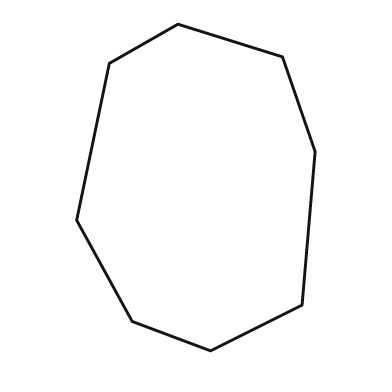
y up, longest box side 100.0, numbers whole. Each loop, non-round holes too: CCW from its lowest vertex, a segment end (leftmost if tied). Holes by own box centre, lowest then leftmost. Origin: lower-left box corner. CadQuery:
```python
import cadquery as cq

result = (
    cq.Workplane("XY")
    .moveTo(41.0, 0.0)
    .lineTo(69.0, 14.0)
    .lineTo(73.0, 61.0)
    .lineTo(63.0, 90.0)
    .lineTo(31.0, 100.0)
    .lineTo(10.0, 88.0)
    .lineTo(0.0, 40.0)
    .lineTo(17.0, 9.0)
    .close()
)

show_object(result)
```